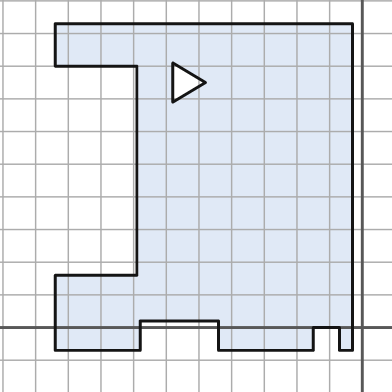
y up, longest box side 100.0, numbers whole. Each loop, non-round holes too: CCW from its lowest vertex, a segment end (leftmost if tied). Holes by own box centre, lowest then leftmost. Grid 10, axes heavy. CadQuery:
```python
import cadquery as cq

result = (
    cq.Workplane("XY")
    .moveTo(-94.0, -7.0)
    .lineTo(-68.0, -7.0)
    .lineTo(-68.0, 2.0)
    .lineTo(-44.0, 2.0)
    .lineTo(-44.0, -7.0)
    .lineTo(-15.0, -7.0)
    .lineTo(-15.0, 0.0)
    .lineTo(-7.0, 0.0)
    .lineTo(-7.0, -7.0)
    .lineTo(-3.0, -7.0)
    .lineTo(-3.0, 93.0)
    .lineTo(-94.0, 93.0)
    .lineTo(-94.0, 80.0)
    .lineTo(-69.0, 80.0)
    .lineTo(-69.0, 16.0)
    .lineTo(-94.0, 16.0)
    .close()
    .moveTo(-58.0, 69.0)
    .lineTo(-48.0, 75.0)
    .lineTo(-58.0, 81.0)
    .close()
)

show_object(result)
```